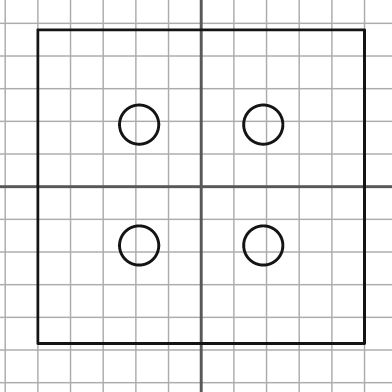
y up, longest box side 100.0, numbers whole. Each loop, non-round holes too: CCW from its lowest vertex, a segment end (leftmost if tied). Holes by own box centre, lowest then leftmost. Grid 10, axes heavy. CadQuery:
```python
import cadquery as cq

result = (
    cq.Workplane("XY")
    .moveTo(-50.0, -48.0)
    .lineTo(50.0, -48.0)
    .lineTo(50.0, 48.0)
    .lineTo(-50.0, 48.0)
    .close()
    .moveTo(-19.0, -18.0)
    .circle(6.0)
    .moveTo(19.0, -18.0)
    .circle(6.0)
    .moveTo(-19.0, 19.0)
    .circle(6.0)
    .moveTo(19.0, 19.0)
    .circle(6.0)
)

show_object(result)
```